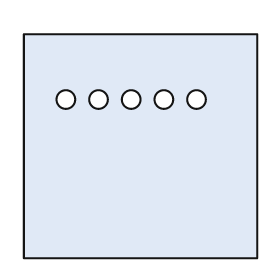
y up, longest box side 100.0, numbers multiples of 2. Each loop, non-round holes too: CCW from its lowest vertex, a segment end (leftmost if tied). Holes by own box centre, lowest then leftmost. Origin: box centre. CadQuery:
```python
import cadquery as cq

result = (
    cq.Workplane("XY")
    .moveTo(-50.0, -48.0)
    .lineTo(50.0, -48.0)
    .lineTo(50.0, 48.0)
    .lineTo(-50.0, 48.0)
    .close()
    .moveTo(-32.0, 20.0)
    .circle(4.0)
    .moveTo(-18.0, 20.0)
    .circle(4.0)
    .moveTo(-4.0, 20.0)
    .circle(4.0)
    .moveTo(10.0, 20.0)
    .circle(4.0)
    .moveTo(24.0, 20.0)
    .circle(4.0)
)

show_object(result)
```